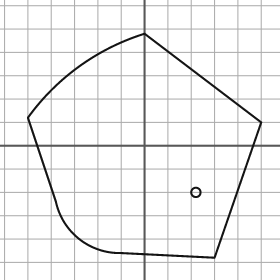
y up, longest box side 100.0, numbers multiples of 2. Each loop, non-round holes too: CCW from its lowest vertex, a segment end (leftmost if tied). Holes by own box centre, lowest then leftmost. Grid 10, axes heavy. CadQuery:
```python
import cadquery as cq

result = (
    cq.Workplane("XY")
    .moveTo(30.0, -48.0)
    .lineTo(50.0, 10.0)
    .lineTo(0.0, 48.0)
    .threePointArc((-28.0, 34.0), (-50.0, 12.0))
    .lineTo(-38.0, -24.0)
    .threePointArc((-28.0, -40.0), (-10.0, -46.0))
    .close()
    .moveTo(22.0, -20.0)
    .circle(2.0)
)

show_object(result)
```